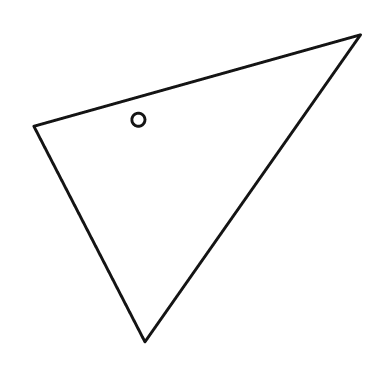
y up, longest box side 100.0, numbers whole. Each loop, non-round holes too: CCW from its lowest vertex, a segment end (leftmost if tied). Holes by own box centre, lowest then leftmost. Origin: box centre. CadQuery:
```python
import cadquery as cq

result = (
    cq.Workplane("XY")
    .moveTo(-16.0, -47.0)
    .lineTo(50.0, 47.0)
    .lineTo(-50.0, 19.0)
    .close()
    .moveTo(-18.0, 21.0)
    .circle(2.0)
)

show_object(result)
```